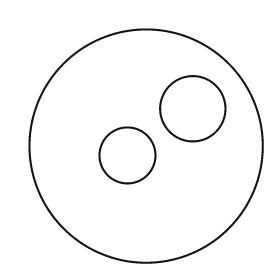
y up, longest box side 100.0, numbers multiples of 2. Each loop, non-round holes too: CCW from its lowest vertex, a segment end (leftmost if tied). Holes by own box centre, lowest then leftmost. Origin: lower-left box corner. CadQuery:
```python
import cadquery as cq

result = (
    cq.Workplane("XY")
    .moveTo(50.0, 50.0)
    .circle(50.0)
    .moveTo(42.0, 46.0)
    .circle(12.0)
    .moveTo(70.0, 66.0)
    .circle(14.0)
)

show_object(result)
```